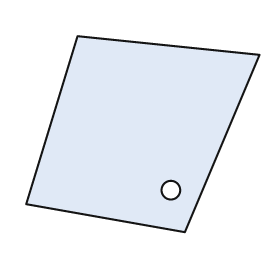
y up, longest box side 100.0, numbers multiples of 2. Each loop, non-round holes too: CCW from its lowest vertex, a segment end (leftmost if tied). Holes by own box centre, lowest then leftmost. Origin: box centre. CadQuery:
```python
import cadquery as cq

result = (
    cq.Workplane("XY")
    .moveTo(18.0, -42.0)
    .lineTo(50.0, 34.0)
    .lineTo(-28.0, 42.0)
    .lineTo(-50.0, -30.0)
    .close()
    .moveTo(12.0, -24.0)
    .circle(4.0)
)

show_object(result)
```